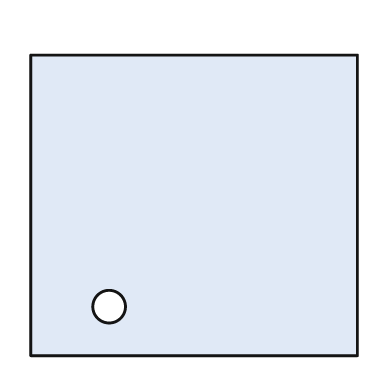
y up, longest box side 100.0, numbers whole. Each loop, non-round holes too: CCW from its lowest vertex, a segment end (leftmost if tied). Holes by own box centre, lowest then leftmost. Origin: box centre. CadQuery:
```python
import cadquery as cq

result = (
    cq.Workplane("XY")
    .moveTo(-50.0, -46.0)
    .lineTo(50.0, -46.0)
    .lineTo(50.0, 46.0)
    .lineTo(-50.0, 46.0)
    .close()
    .moveTo(-26.0, -31.0)
    .circle(5.0)
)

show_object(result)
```